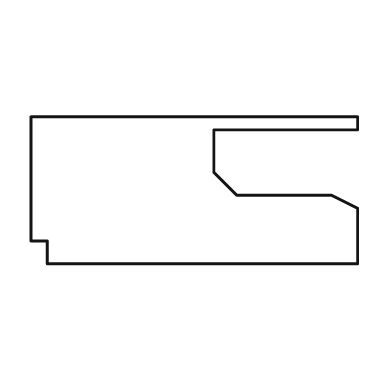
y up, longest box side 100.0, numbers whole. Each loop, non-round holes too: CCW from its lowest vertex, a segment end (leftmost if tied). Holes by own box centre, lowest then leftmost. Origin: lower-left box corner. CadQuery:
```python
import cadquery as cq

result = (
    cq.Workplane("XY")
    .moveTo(5.0, 0.0)
    .lineTo(100.0, 0.0)
    .lineTo(100.0, 17.0)
    .lineTo(92.0, 21.0)
    .lineTo(63.0, 21.0)
    .lineTo(56.0, 28.0)
    .lineTo(56.0, 41.0)
    .lineTo(100.0, 41.0)
    .lineTo(100.0, 45.0)
    .lineTo(0.0, 45.0)
    .lineTo(0.0, 7.0)
    .lineTo(5.0, 7.0)
    .close()
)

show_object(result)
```